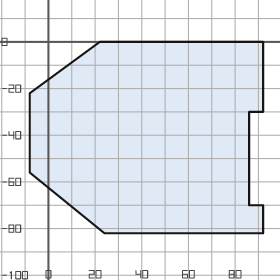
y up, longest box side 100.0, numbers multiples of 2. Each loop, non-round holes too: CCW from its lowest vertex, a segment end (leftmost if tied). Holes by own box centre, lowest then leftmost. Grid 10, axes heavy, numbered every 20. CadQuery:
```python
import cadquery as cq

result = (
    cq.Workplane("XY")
    .moveTo(24.0, -82.0)
    .lineTo(92.0, -82.0)
    .lineTo(92.0, -70.0)
    .lineTo(86.0, -70.0)
    .lineTo(86.0, -30.0)
    .lineTo(92.0, -30.0)
    .lineTo(92.0, 0.0)
    .lineTo(22.0, 0.0)
    .lineTo(-8.0, -22.0)
    .lineTo(-8.0, -56.0)
    .close()
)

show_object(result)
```